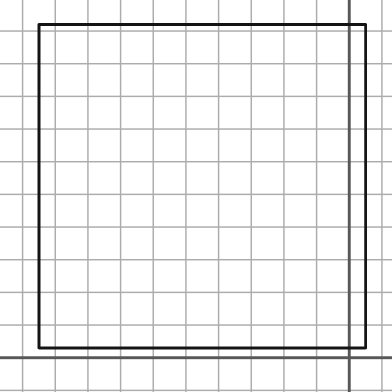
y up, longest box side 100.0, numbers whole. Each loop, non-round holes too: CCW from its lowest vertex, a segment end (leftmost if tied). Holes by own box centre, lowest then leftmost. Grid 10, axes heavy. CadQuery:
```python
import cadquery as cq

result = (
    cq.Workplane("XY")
    .moveTo(-95.0, 3.0)
    .lineTo(5.0, 3.0)
    .lineTo(5.0, 102.0)
    .lineTo(-95.0, 102.0)
    .close()
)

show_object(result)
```